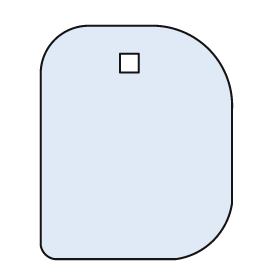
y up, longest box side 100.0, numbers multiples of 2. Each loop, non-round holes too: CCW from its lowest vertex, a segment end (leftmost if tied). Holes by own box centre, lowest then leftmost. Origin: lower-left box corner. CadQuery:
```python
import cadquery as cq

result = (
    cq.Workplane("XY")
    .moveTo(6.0, 0.0)
    .lineTo(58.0, 0.0)
    .threePointArc((74.0, 8.0), (82.0, 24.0))
    .lineTo(82.0, 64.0)
    .threePointArc((72.0, 90.0), (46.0, 100.0))
    .lineTo(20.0, 100.0)
    .threePointArc((6.0, 94.0), (0.0, 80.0))
    .lineTo(0.0, 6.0)
    .threePointArc((2.0, 2.0), (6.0, 0.0))
    .close()
    .moveTo(34.0, 80.0)
    .lineTo(42.0, 80.0)
    .lineTo(42.0, 88.0)
    .lineTo(34.0, 88.0)
    .close()
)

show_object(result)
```